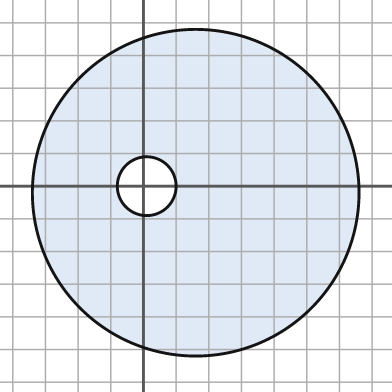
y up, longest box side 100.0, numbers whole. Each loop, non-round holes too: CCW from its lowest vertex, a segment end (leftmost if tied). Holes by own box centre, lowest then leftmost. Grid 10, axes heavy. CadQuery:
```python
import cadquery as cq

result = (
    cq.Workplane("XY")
    .moveTo(16.0, -2.0)
    .circle(50.0)
    .moveTo(1.0, 0.0)
    .circle(9.0)
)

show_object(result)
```